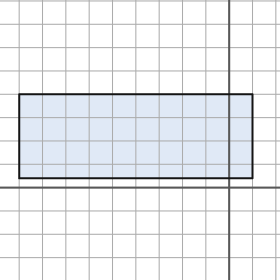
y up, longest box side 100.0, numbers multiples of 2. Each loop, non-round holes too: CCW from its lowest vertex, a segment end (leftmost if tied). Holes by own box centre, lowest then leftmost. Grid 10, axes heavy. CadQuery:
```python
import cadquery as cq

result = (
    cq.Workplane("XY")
    .moveTo(-90.0, 4.0)
    .lineTo(10.0, 4.0)
    .lineTo(10.0, 40.0)
    .lineTo(-90.0, 40.0)
    .close()
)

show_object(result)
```